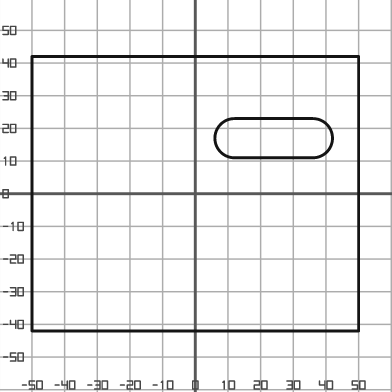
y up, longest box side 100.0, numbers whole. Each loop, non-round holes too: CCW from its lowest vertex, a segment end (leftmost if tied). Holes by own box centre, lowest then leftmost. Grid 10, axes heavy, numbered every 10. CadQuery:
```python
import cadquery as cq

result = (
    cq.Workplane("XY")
    .moveTo(-50.0, -42.0)
    .lineTo(50.0, -42.0)
    .lineTo(50.0, 42.0)
    .lineTo(-50.0, 42.0)
    .close()
    .moveTo(12.0, 11.0)
    .lineTo(36.0, 11.0)
    .threePointArc((42.0, 17.0), (36.0, 23.0))
    .lineTo(12.0, 23.0)
    .threePointArc((6.0, 17.0), (12.0, 11.0))
    .close()
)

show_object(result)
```